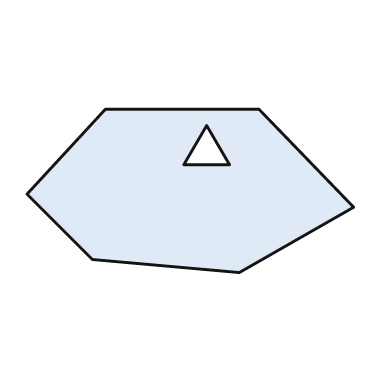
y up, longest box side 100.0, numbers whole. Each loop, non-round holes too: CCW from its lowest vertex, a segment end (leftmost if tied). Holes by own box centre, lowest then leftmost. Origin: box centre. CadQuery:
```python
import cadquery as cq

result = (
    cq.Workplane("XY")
    .moveTo(15.0, -25.0)
    .lineTo(50.0, -5.0)
    .lineTo(21.0, 25.0)
    .lineTo(-26.0, 25.0)
    .lineTo(-50.0, -1.0)
    .lineTo(-30.0, -21.0)
    .close()
    .moveTo(-2.0, 8.0)
    .lineTo(12.0, 8.0)
    .lineTo(5.0, 20.0)
    .close()
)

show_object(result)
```